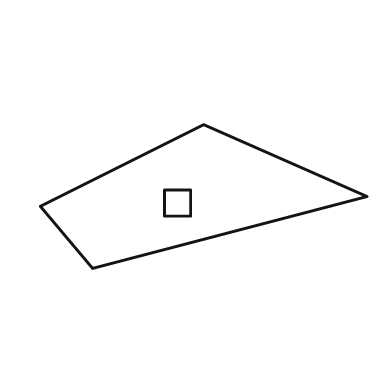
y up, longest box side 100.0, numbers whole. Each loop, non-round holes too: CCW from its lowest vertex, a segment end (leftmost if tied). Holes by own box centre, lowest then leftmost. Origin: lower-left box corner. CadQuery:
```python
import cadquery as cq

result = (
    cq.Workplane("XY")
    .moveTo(16.0, 0.0)
    .lineTo(100.0, 22.0)
    .lineTo(50.0, 44.0)
    .lineTo(0.0, 19.0)
    .close()
    .moveTo(38.0, 16.0)
    .lineTo(46.0, 16.0)
    .lineTo(46.0, 24.0)
    .lineTo(38.0, 24.0)
    .close()
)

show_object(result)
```